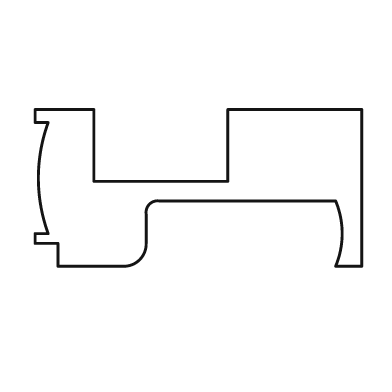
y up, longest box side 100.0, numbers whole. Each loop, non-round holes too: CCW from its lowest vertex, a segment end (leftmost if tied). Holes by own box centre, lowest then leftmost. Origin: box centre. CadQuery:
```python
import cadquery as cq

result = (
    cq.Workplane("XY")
    .moveTo(-43.0, -24.0)
    .lineTo(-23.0, -24.0)
    .threePointArc((-18.0, -22.0), (-16.0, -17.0))
    .lineTo(-16.0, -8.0)
    .threePointArc((-15.0, -5.0), (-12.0, -4.0))
    .lineTo(42.0, -4.0)
    .threePointArc((44.0, -14.0), (42.0, -24.0))
    .lineTo(50.0, -24.0)
    .lineTo(50.0, 24.0)
    .lineTo(9.0, 24.0)
    .lineTo(9.0, 2.0)
    .lineTo(-32.0, 2.0)
    .lineTo(-32.0, 24.0)
    .lineTo(-50.0, 24.0)
    .lineTo(-50.0, 20.0)
    .lineTo(-46.0, 20.0)
    .threePointArc((-49.0, 3.0), (-46.0, -14.0))
    .lineTo(-50.0, -14.0)
    .lineTo(-50.0, -17.0)
    .lineTo(-43.0, -17.0)
    .close()
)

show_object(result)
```